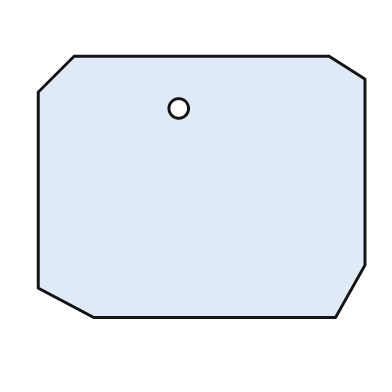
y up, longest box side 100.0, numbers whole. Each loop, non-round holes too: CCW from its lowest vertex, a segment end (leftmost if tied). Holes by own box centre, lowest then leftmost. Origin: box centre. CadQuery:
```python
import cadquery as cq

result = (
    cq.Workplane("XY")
    .moveTo(-33.0, -40.0)
    .lineTo(41.0, -40.0)
    .lineTo(50.0, -24.0)
    .lineTo(50.0, 33.0)
    .lineTo(39.0, 40.0)
    .lineTo(-39.0, 40.0)
    .lineTo(-50.0, 29.0)
    .lineTo(-50.0, -31.0)
    .close()
    .moveTo(-7.0, 24.0)
    .circle(3.0)
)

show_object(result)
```